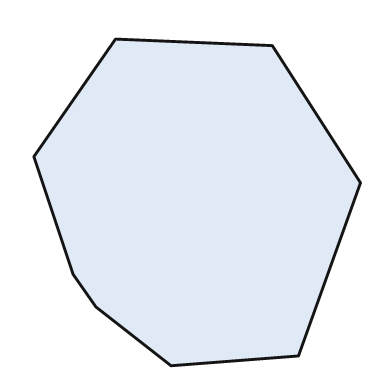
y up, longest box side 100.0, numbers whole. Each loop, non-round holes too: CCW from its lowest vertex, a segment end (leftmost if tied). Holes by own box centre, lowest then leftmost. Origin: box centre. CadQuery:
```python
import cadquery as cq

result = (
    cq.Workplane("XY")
    .moveTo(-8.0, -50.0)
    .lineTo(31.0, -47.0)
    .lineTo(50.0, 6.0)
    .lineTo(23.0, 48.0)
    .lineTo(-25.0, 50.0)
    .lineTo(-50.0, 14.0)
    .lineTo(-38.0, -22.0)
    .lineTo(-31.0, -32.0)
    .close()
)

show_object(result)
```